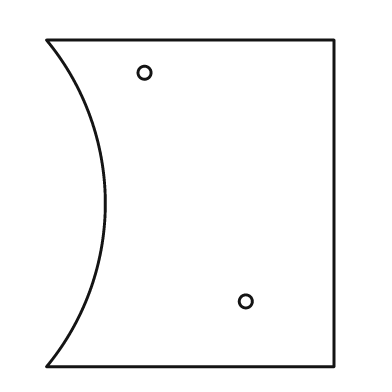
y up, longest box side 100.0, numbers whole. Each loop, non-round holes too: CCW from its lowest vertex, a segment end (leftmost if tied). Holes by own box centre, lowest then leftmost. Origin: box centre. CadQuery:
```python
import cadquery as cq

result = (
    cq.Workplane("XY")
    .moveTo(-44.0, -50.0)
    .lineTo(44.0, -50.0)
    .lineTo(44.0, 50.0)
    .lineTo(-44.0, 50.0)
    .threePointArc((-26.0, 0.0), (-44.0, -50.0))
    .close()
    .moveTo(17.0, -30.0)
    .circle(2.0)
    .moveTo(-14.0, 40.0)
    .circle(2.0)
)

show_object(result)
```